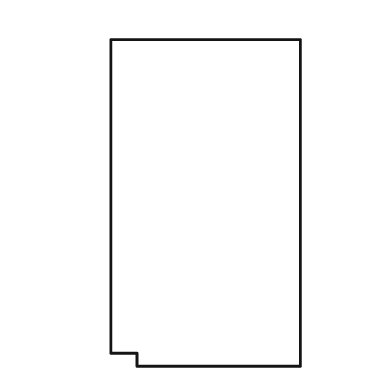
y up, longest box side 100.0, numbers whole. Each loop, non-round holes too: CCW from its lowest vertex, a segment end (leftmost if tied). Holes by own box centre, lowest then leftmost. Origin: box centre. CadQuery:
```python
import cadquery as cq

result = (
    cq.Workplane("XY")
    .moveTo(-21.0, -50.0)
    .lineTo(29.0, -50.0)
    .lineTo(29.0, 50.0)
    .lineTo(-29.0, 50.0)
    .lineTo(-29.0, -46.0)
    .lineTo(-21.0, -46.0)
    .close()
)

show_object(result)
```